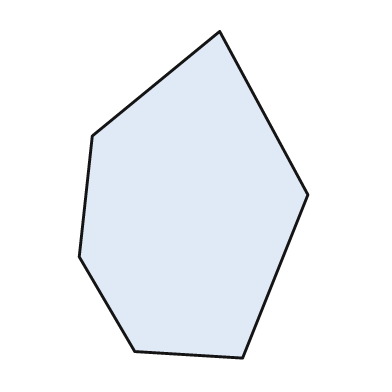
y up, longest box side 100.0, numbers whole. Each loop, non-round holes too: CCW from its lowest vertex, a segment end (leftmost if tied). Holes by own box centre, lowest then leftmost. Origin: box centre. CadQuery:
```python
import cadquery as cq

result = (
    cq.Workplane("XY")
    .moveTo(15.0, -50.0)
    .lineTo(35.0, 0.0)
    .lineTo(8.0, 50.0)
    .lineTo(-31.0, 18.0)
    .lineTo(-35.0, -19.0)
    .lineTo(-18.0, -48.0)
    .close()
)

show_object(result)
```